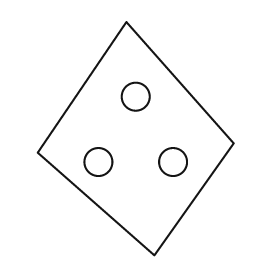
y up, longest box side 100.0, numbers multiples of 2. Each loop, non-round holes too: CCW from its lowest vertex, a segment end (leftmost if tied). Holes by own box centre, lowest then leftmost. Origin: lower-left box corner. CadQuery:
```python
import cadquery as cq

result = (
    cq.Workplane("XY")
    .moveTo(50.0, 0.0)
    .lineTo(84.0, 48.0)
    .lineTo(38.0, 100.0)
    .lineTo(0.0, 44.0)
    .close()
    .moveTo(26.0, 40.0)
    .circle(6.0)
    .moveTo(58.0, 40.0)
    .circle(6.0)
    .moveTo(42.0, 68.0)
    .circle(6.0)
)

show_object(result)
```